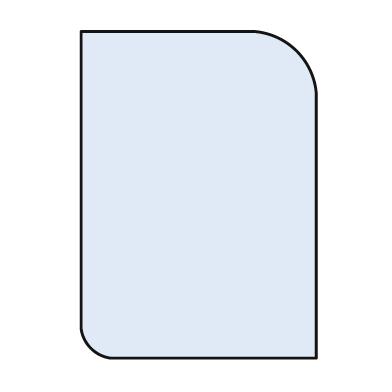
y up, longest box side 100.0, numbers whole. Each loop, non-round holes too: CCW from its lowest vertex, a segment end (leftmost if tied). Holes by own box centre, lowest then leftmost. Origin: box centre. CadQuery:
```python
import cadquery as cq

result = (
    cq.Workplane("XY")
    .moveTo(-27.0, -50.0)
    .lineTo(36.0, -50.0)
    .lineTo(36.0, 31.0)
    .threePointArc((30.0, 44.0), (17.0, 50.0))
    .lineTo(-36.0, 50.0)
    .lineTo(-36.0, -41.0)
    .threePointArc((-33.0, -47.0), (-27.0, -50.0))
    .close()
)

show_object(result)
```